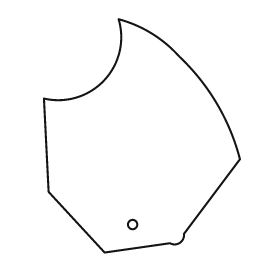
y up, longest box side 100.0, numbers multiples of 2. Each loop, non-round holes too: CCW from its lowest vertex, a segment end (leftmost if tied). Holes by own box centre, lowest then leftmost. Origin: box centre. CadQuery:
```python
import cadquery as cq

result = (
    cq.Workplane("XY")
    .moveTo(-16.0, -50.0)
    .lineTo(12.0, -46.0)
    .threePointArc((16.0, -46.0), (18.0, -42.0))
    .lineTo(42.0, -10.0)
    .threePointArc((32.0, 14.0), (16.0, 34.0))
    .threePointArc((4.0, 44.0), (-10.0, 50.0))
    .threePointArc((-16.0, 24.0), (-42.0, 16.0))
    .lineTo(-40.0, -24.0)
    .close()
    .moveTo(-4.0, -38.0)
    .circle(2.0)
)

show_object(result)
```